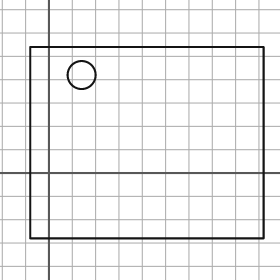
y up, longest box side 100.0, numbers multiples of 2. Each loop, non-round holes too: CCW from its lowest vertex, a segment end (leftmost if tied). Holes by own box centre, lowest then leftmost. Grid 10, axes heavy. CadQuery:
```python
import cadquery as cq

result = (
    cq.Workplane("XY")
    .moveTo(-8.0, -28.0)
    .lineTo(92.0, -28.0)
    .lineTo(92.0, 54.0)
    .lineTo(-8.0, 54.0)
    .close()
    .moveTo(14.0, 42.0)
    .circle(6.0)
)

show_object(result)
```